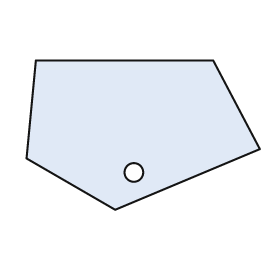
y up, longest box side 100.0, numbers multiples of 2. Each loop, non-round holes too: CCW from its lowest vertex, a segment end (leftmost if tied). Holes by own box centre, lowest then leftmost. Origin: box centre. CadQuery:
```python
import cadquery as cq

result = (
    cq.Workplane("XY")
    .moveTo(-12.0, -32.0)
    .lineTo(50.0, -6.0)
    .lineTo(30.0, 32.0)
    .lineTo(-46.0, 32.0)
    .lineTo(-50.0, -10.0)
    .close()
    .moveTo(-4.0, -16.0)
    .circle(4.0)
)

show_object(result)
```